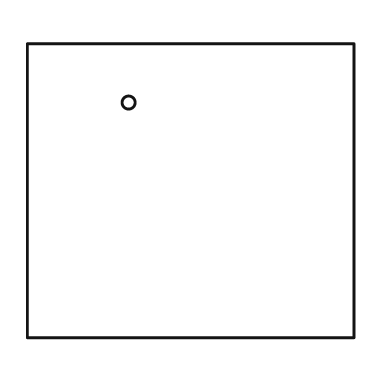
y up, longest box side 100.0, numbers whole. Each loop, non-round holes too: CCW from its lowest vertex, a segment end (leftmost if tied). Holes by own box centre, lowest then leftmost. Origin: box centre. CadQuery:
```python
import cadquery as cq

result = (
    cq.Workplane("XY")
    .moveTo(-50.0, -45.0)
    .lineTo(50.0, -45.0)
    .lineTo(50.0, 45.0)
    .lineTo(-50.0, 45.0)
    .close()
    .moveTo(-19.0, 27.0)
    .circle(2.0)
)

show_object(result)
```